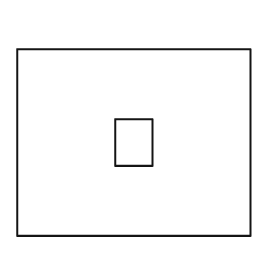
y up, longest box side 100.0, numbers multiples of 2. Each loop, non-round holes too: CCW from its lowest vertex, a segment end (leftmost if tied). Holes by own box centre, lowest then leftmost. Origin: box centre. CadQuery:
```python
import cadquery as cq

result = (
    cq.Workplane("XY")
    .moveTo(-50.0, -40.0)
    .lineTo(50.0, -40.0)
    .lineTo(50.0, 40.0)
    .lineTo(-50.0, 40.0)
    .close()
    .moveTo(-8.0, -10.0)
    .lineTo(8.0, -10.0)
    .lineTo(8.0, 10.0)
    .lineTo(-8.0, 10.0)
    .close()
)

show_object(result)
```